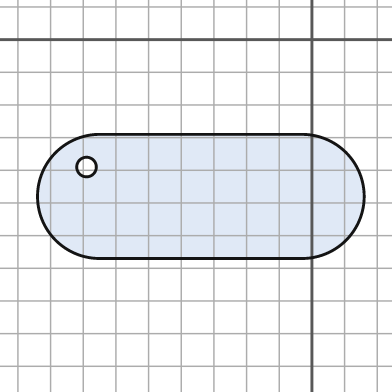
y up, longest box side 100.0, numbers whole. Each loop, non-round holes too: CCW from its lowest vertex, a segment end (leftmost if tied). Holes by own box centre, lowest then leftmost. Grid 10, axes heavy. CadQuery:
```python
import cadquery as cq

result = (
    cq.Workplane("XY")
    .moveTo(-65.0, -67.0)
    .lineTo(-3.0, -67.0)
    .threePointArc((16.0, -48.0), (-3.0, -29.0))
    .lineTo(-65.0, -29.0)
    .threePointArc((-84.0, -48.0), (-65.0, -67.0))
    .close()
    .moveTo(-69.0, -39.0)
    .circle(3.0)
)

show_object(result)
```